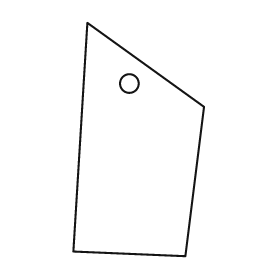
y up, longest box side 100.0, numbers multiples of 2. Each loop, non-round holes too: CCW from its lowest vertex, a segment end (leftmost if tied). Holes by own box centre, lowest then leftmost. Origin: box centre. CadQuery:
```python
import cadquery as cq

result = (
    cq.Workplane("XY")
    .moveTo(20.0, -50.0)
    .lineTo(28.0, 14.0)
    .lineTo(-22.0, 50.0)
    .lineTo(-28.0, -48.0)
    .close()
    .moveTo(-4.0, 24.0)
    .circle(4.0)
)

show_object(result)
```